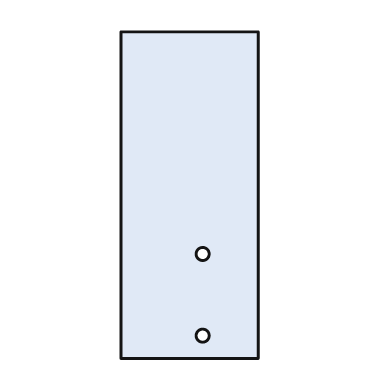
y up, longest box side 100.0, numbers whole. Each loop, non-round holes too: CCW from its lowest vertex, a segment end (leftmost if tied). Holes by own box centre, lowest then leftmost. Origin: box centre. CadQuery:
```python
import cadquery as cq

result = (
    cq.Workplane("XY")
    .moveTo(-21.0, -50.0)
    .lineTo(21.0, -50.0)
    .lineTo(21.0, 50.0)
    .lineTo(-21.0, 50.0)
    .close()
    .moveTo(4.0, -43.0)
    .circle(2.0)
    .moveTo(4.0, -18.0)
    .circle(2.0)
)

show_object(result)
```